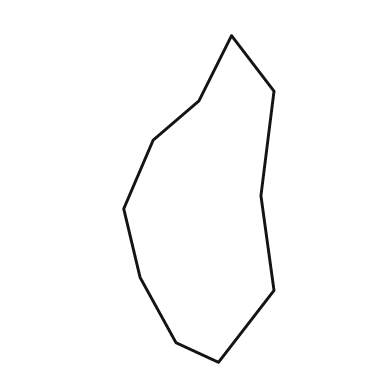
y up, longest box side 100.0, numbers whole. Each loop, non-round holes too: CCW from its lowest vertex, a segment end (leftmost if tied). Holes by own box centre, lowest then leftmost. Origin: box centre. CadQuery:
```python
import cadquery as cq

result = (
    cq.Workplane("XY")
    .moveTo(6.0, -50.0)
    .lineTo(23.0, -28.0)
    .lineTo(19.0, 1.0)
    .lineTo(23.0, 33.0)
    .lineTo(10.0, 50.0)
    .lineTo(0.0, 30.0)
    .lineTo(-14.0, 18.0)
    .lineTo(-23.0, -3.0)
    .lineTo(-18.0, -24.0)
    .lineTo(-7.0, -44.0)
    .close()
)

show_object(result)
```